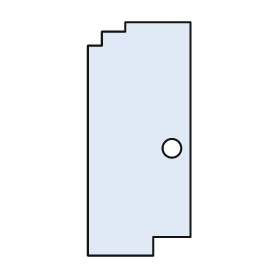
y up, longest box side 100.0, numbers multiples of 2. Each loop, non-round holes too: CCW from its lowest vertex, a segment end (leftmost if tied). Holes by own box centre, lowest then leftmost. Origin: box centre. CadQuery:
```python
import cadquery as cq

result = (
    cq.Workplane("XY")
    .moveTo(-22.0, -50.0)
    .lineTo(6.0, -50.0)
    .lineTo(6.0, -42.0)
    .lineTo(22.0, -42.0)
    .lineTo(22.0, 50.0)
    .lineTo(-6.0, 50.0)
    .lineTo(-6.0, 46.0)
    .lineTo(-16.0, 46.0)
    .lineTo(-16.0, 40.0)
    .lineTo(-22.0, 40.0)
    .close()
    .moveTo(14.0, -4.0)
    .circle(4.0)
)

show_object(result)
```